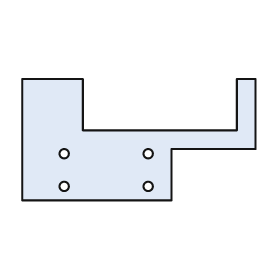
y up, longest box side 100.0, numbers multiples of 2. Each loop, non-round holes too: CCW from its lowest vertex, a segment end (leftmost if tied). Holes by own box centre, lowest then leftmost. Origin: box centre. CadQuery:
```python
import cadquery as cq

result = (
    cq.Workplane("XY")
    .moveTo(-50.0, -26.0)
    .lineTo(14.0, -26.0)
    .lineTo(14.0, -4.0)
    .lineTo(50.0, -4.0)
    .lineTo(50.0, 26.0)
    .lineTo(42.0, 26.0)
    .lineTo(42.0, 4.0)
    .lineTo(-24.0, 4.0)
    .lineTo(-24.0, 26.0)
    .lineTo(-50.0, 26.0)
    .close()
    .moveTo(-32.0, -20.0)
    .circle(2.0)
    .moveTo(4.0, -20.0)
    .circle(2.0)
    .moveTo(-32.0, -6.0)
    .circle(2.0)
    .moveTo(4.0, -6.0)
    .circle(2.0)
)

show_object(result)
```